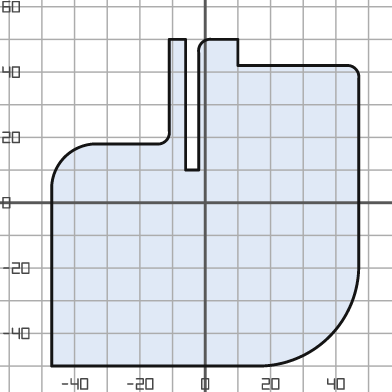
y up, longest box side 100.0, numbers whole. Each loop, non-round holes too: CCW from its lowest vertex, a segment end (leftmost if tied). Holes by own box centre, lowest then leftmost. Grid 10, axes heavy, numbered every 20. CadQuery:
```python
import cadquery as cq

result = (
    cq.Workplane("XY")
    .moveTo(-47.0, -50.0)
    .lineTo(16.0, -50.0)
    .threePointArc((38.0, -41.0), (47.0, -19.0))
    .lineTo(47.0, 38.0)
    .threePointArc((46.0, 41.0), (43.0, 42.0))
    .lineTo(10.0, 42.0)
    .lineTo(10.0, 50.0)
    .lineTo(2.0, 50.0)
    .threePointArc((-1.0, 49.0), (-2.0, 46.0))
    .lineTo(-2.0, 10.0)
    .lineTo(-6.0, 10.0)
    .lineTo(-6.0, 50.0)
    .lineTo(-11.0, 50.0)
    .lineTo(-11.0, 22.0)
    .threePointArc((-12.0, 19.0), (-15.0, 18.0))
    .lineTo(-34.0, 18.0)
    .threePointArc((-43.0, 14.0), (-47.0, 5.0))
    .close()
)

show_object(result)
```